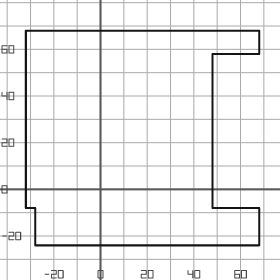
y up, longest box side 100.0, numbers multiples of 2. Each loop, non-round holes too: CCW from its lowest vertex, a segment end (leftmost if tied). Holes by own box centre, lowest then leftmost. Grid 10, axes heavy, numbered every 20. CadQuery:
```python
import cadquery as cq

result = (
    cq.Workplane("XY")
    .moveTo(-28.0, -24.0)
    .lineTo(68.0, -24.0)
    .lineTo(68.0, -8.0)
    .lineTo(48.0, -8.0)
    .lineTo(48.0, 58.0)
    .lineTo(68.0, 58.0)
    .lineTo(68.0, 68.0)
    .lineTo(-32.0, 68.0)
    .lineTo(-32.0, -8.0)
    .lineTo(-28.0, -8.0)
    .close()
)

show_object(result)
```